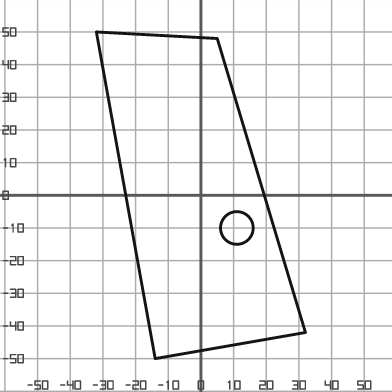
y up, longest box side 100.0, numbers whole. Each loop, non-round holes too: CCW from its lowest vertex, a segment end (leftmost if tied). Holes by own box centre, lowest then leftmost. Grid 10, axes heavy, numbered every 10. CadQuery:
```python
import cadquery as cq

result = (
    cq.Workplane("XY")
    .moveTo(-14.0, -50.0)
    .lineTo(32.0, -42.0)
    .lineTo(5.0, 48.0)
    .lineTo(-32.0, 50.0)
    .close()
    .moveTo(11.0, -10.0)
    .circle(5.0)
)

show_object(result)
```